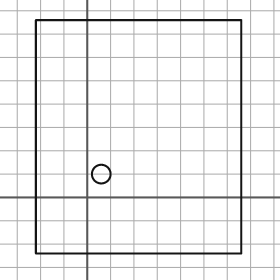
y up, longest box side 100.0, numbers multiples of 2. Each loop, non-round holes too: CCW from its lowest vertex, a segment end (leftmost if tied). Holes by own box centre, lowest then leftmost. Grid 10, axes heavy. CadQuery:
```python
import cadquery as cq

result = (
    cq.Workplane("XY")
    .moveTo(-22.0, -24.0)
    .lineTo(66.0, -24.0)
    .lineTo(66.0, 76.0)
    .lineTo(-22.0, 76.0)
    .close()
    .moveTo(6.0, 10.0)
    .circle(4.0)
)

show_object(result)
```